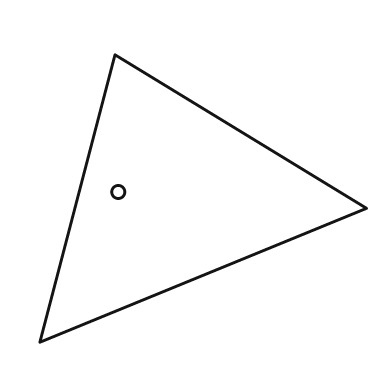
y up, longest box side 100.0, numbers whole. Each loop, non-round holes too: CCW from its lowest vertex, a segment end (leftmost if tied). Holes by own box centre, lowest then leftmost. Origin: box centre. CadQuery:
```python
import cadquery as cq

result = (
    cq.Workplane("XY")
    .moveTo(-50.0, -44.0)
    .lineTo(50.0, -3.0)
    .lineTo(-27.0, 44.0)
    .close()
    .moveTo(-26.0, 2.0)
    .circle(2.0)
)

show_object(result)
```